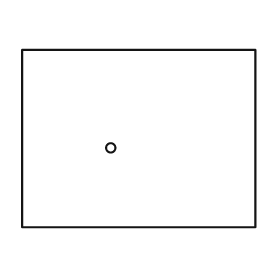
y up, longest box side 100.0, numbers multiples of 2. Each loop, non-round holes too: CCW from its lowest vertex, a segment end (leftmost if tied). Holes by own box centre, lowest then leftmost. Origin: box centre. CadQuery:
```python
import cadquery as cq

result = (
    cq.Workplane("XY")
    .moveTo(-50.0, -38.0)
    .lineTo(50.0, -38.0)
    .lineTo(50.0, 38.0)
    .lineTo(-50.0, 38.0)
    .close()
    .moveTo(-12.0, -4.0)
    .circle(2.0)
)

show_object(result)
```